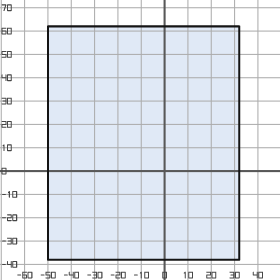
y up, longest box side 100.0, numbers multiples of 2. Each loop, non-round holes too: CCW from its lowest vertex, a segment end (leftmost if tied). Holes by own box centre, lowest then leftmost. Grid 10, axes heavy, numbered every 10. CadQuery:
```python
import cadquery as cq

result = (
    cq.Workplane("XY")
    .moveTo(-50.0, -38.0)
    .lineTo(32.0, -38.0)
    .lineTo(32.0, 62.0)
    .lineTo(-50.0, 62.0)
    .close()
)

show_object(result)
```